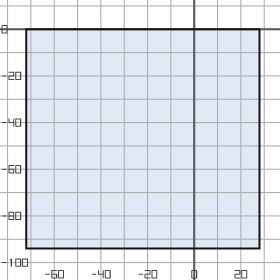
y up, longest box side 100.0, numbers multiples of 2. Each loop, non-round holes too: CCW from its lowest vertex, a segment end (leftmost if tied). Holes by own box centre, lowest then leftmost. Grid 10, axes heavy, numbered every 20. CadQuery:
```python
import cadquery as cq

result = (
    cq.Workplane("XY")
    .moveTo(-72.0, -94.0)
    .lineTo(28.0, -94.0)
    .lineTo(28.0, 0.0)
    .lineTo(-72.0, 0.0)
    .close()
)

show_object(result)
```